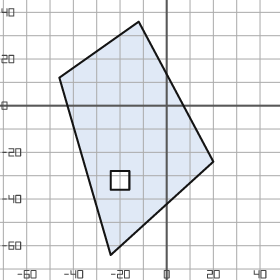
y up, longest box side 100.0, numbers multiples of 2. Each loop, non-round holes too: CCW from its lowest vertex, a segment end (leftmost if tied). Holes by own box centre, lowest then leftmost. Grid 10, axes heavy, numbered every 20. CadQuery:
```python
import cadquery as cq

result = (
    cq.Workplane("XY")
    .moveTo(-24.0, -64.0)
    .lineTo(20.0, -24.0)
    .lineTo(-12.0, 36.0)
    .lineTo(-46.0, 12.0)
    .close()
    .moveTo(-24.0, -36.0)
    .lineTo(-16.0, -36.0)
    .lineTo(-16.0, -28.0)
    .lineTo(-24.0, -28.0)
    .close()
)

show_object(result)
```